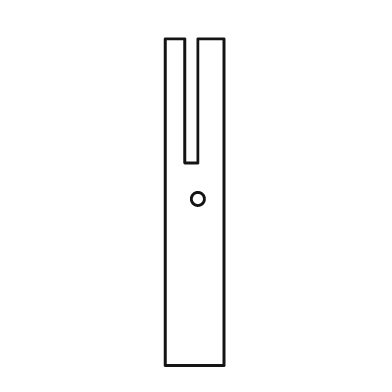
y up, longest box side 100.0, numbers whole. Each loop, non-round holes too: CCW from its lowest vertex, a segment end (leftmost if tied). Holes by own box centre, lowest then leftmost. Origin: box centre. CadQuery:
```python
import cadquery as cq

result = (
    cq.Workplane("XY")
    .moveTo(-9.0, -50.0)
    .lineTo(9.0, -50.0)
    .lineTo(9.0, 50.0)
    .lineTo(1.0, 50.0)
    .lineTo(1.0, 12.0)
    .lineTo(-3.0, 12.0)
    .lineTo(-3.0, 50.0)
    .lineTo(-9.0, 50.0)
    .close()
    .moveTo(1.0, 1.0)
    .circle(2.0)
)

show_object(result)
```